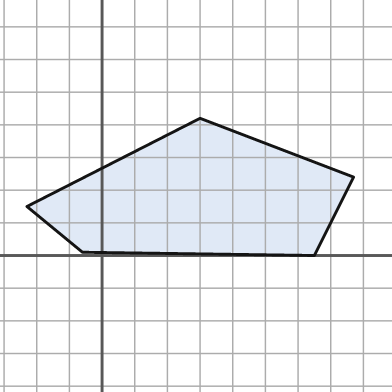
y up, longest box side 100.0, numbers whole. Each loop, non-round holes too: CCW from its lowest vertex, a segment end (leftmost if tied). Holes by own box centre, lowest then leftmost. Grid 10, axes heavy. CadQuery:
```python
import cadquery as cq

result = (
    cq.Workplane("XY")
    .moveTo(65.0, 0.0)
    .lineTo(77.0, 24.0)
    .lineTo(30.0, 42.0)
    .lineTo(-23.0, 15.0)
    .lineTo(-6.0, 1.0)
    .close()
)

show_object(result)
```